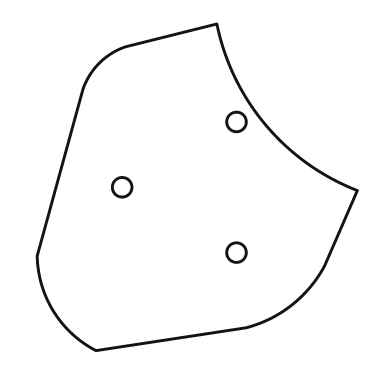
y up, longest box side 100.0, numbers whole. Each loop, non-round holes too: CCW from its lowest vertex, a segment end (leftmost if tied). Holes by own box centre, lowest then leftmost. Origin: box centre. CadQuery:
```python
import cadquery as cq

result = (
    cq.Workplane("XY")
    .moveTo(-31.0, -50.0)
    .lineTo(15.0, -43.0)
    .threePointArc((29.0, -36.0), (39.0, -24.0))
    .lineTo(49.0, -1.0)
    .threePointArc((21.0, 19.0), (6.0, 50.0))
    .lineTo(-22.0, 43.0)
    .threePointArc((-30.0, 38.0), (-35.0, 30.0))
    .lineTo(-49.0, -21.0)
    .threePointArc((-44.0, -38.0), (-31.0, -50.0))
    .close()
    .moveTo(12.0, -20.0)
    .circle(3.0)
    .moveTo(-23.0, 0.0)
    .circle(3.0)
    .moveTo(12.0, 20.0)
    .circle(3.0)
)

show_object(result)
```